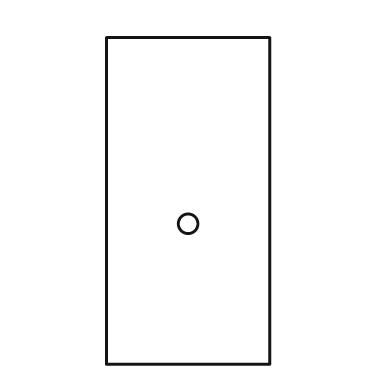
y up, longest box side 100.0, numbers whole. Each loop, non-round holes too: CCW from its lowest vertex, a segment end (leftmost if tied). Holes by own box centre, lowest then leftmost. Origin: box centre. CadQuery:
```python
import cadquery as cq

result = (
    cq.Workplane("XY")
    .moveTo(-25.0, -50.0)
    .lineTo(25.0, -50.0)
    .lineTo(25.0, 50.0)
    .lineTo(-25.0, 50.0)
    .close()
    .moveTo(0.0, -7.0)
    .circle(3.0)
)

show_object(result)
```